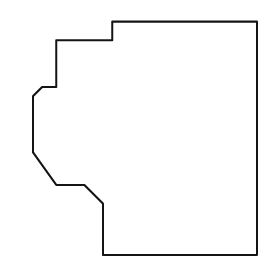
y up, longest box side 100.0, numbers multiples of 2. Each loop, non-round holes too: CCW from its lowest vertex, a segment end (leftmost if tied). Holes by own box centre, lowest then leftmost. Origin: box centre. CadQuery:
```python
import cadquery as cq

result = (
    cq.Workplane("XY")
    .moveTo(-18.0, -50.0)
    .lineTo(48.0, -50.0)
    .lineTo(48.0, 50.0)
    .lineTo(-14.0, 50.0)
    .lineTo(-14.0, 42.0)
    .lineTo(-38.0, 42.0)
    .lineTo(-38.0, 22.0)
    .lineTo(-44.0, 22.0)
    .lineTo(-48.0, 18.0)
    .lineTo(-48.0, -6.0)
    .lineTo(-38.0, -20.0)
    .lineTo(-26.0, -20.0)
    .lineTo(-18.0, -28.0)
    .close()
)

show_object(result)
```